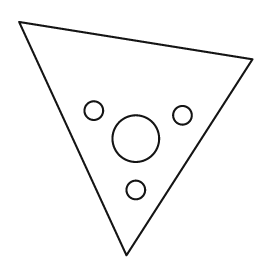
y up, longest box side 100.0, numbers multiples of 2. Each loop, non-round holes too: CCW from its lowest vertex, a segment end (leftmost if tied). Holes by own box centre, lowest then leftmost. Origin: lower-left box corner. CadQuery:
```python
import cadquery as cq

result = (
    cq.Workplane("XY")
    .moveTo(46.0, 0.0)
    .lineTo(100.0, 84.0)
    .lineTo(0.0, 100.0)
    .close()
    .moveTo(50.0, 28.0)
    .circle(4.0)
    .moveTo(50.0, 50.0)
    .circle(10.0)
    .moveTo(70.0, 60.0)
    .circle(4.0)
    .moveTo(32.0, 62.0)
    .circle(4.0)
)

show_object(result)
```